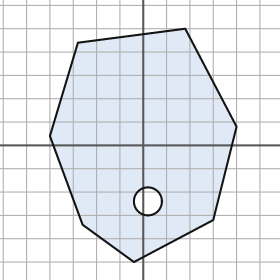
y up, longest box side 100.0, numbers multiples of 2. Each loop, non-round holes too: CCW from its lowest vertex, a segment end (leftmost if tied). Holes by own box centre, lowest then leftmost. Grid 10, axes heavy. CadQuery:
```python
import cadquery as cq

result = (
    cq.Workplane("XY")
    .moveTo(-4.0, -50.0)
    .lineTo(30.0, -32.0)
    .lineTo(40.0, 8.0)
    .lineTo(18.0, 50.0)
    .lineTo(-28.0, 44.0)
    .lineTo(-40.0, 4.0)
    .lineTo(-26.0, -34.0)
    .close()
    .moveTo(2.0, -24.0)
    .circle(6.0)
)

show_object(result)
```